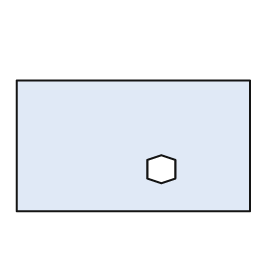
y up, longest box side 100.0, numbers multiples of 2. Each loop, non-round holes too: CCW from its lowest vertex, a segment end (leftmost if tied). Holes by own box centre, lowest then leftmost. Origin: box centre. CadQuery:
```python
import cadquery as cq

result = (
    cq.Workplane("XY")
    .moveTo(-50.0, -28.0)
    .lineTo(50.0, -28.0)
    .lineTo(50.0, 28.0)
    .lineTo(-50.0, 28.0)
    .close()
    .moveTo(12.0, -16.0)
    .lineTo(18.0, -14.0)
    .lineTo(18.0, -6.0)
    .lineTo(12.0, -4.0)
    .lineTo(6.0, -6.0)
    .lineTo(6.0, -14.0)
    .close()
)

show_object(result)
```